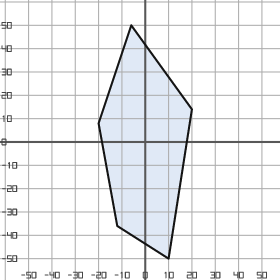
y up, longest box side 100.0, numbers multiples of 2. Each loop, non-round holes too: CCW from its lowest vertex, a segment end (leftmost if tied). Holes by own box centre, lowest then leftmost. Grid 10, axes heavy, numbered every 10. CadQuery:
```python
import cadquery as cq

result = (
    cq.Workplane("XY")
    .moveTo(10.0, -50.0)
    .lineTo(20.0, 14.0)
    .lineTo(-6.0, 50.0)
    .lineTo(-20.0, 8.0)
    .lineTo(-12.0, -36.0)
    .close()
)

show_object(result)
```